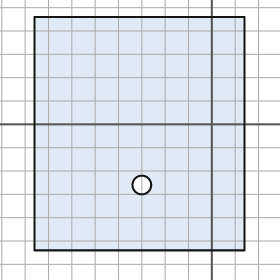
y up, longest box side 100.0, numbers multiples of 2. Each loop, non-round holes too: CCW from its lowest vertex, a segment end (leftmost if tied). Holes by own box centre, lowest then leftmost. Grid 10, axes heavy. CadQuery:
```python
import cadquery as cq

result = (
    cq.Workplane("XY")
    .moveTo(-76.0, -54.0)
    .lineTo(14.0, -54.0)
    .lineTo(14.0, 46.0)
    .lineTo(-76.0, 46.0)
    .close()
    .moveTo(-30.0, -26.0)
    .circle(4.0)
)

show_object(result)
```